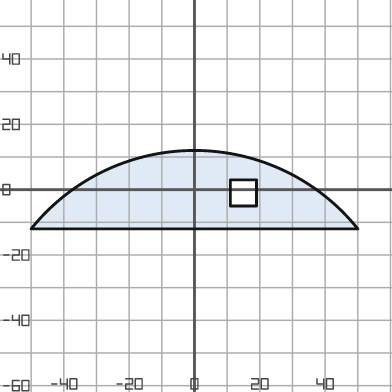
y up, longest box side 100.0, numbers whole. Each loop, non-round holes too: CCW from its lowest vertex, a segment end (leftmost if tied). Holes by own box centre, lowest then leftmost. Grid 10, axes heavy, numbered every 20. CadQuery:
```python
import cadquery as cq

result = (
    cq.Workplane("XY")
    .moveTo(-50.0, -12.0)
    .lineTo(50.0, -12.0)
    .threePointArc((0.0, 12.0), (-50.0, -12.0))
    .close()
    .moveTo(11.0, -5.0)
    .lineTo(19.0, -5.0)
    .lineTo(19.0, 3.0)
    .lineTo(11.0, 3.0)
    .close()
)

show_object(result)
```